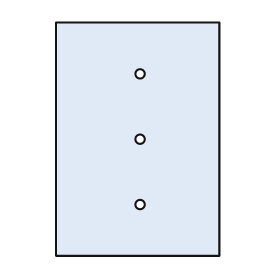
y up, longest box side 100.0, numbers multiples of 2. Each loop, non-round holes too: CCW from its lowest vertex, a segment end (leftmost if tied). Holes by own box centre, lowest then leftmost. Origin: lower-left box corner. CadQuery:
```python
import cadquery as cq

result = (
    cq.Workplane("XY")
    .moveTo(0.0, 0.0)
    .lineTo(70.0, 0.0)
    .lineTo(70.0, 100.0)
    .lineTo(0.0, 100.0)
    .close()
    .moveTo(36.0, 22.0)
    .circle(2.0)
    .moveTo(36.0, 50.0)
    .circle(2.0)
    .moveTo(36.0, 78.0)
    .circle(2.0)
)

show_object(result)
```